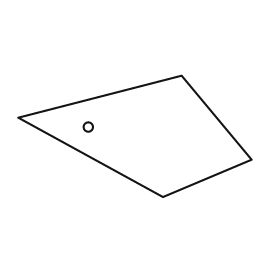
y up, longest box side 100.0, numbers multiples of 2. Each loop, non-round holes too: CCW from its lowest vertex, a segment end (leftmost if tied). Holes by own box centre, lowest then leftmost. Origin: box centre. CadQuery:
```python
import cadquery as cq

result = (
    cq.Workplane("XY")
    .moveTo(12.0, -26.0)
    .lineTo(50.0, -10.0)
    .lineTo(20.0, 26.0)
    .lineTo(-50.0, 8.0)
    .close()
    .moveTo(-20.0, 4.0)
    .circle(2.0)
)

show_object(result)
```